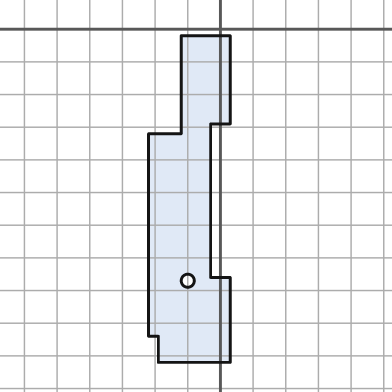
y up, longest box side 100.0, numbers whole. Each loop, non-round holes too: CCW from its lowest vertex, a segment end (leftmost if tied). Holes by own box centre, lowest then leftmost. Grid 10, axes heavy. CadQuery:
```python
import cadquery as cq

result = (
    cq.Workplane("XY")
    .moveTo(-19.0, -102.0)
    .lineTo(3.0, -102.0)
    .lineTo(3.0, -76.0)
    .lineTo(-3.0, -76.0)
    .lineTo(-3.0, -29.0)
    .lineTo(3.0, -29.0)
    .lineTo(3.0, -2.0)
    .lineTo(-12.0, -2.0)
    .lineTo(-12.0, -32.0)
    .lineTo(-22.0, -32.0)
    .lineTo(-22.0, -94.0)
    .lineTo(-19.0, -94.0)
    .close()
    .moveTo(-10.0, -77.0)
    .circle(2.0)
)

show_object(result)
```